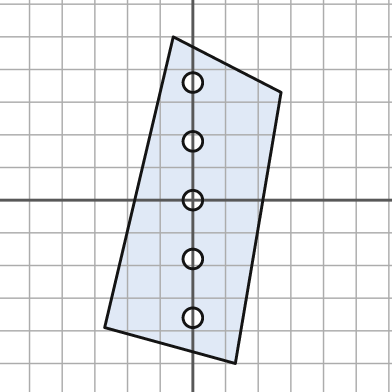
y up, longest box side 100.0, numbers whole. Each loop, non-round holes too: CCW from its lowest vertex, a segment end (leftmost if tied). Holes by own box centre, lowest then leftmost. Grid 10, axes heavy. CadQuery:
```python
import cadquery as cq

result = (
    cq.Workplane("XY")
    .moveTo(13.0, -50.0)
    .lineTo(27.0, 33.0)
    .lineTo(-6.0, 50.0)
    .lineTo(-27.0, -39.0)
    .close()
    .moveTo(0.0, -36.0)
    .circle(3.0)
    .moveTo(0.0, -18.0)
    .circle(3.0)
    .moveTo(0.0, 0.0)
    .circle(3.0)
    .moveTo(0.0, 18.0)
    .circle(3.0)
    .moveTo(0.0, 36.0)
    .circle(3.0)
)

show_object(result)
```